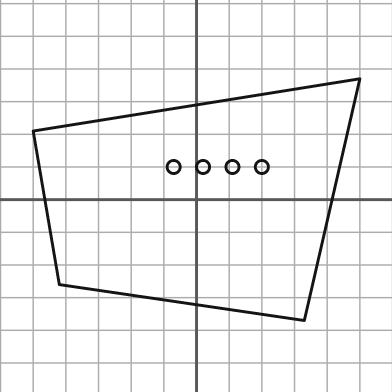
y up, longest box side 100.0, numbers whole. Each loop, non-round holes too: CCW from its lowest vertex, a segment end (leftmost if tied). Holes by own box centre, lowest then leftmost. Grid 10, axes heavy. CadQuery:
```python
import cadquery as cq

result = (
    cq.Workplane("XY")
    .moveTo(33.0, -37.0)
    .lineTo(50.0, 37.0)
    .lineTo(-50.0, 21.0)
    .lineTo(-42.0, -26.0)
    .close()
    .moveTo(-7.0, 10.0)
    .circle(2.0)
    .moveTo(2.0, 10.0)
    .circle(2.0)
    .moveTo(11.0, 10.0)
    .circle(2.0)
    .moveTo(20.0, 10.0)
    .circle(2.0)
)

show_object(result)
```